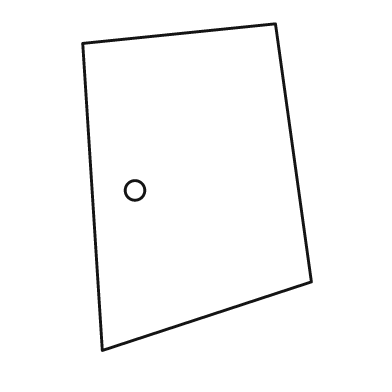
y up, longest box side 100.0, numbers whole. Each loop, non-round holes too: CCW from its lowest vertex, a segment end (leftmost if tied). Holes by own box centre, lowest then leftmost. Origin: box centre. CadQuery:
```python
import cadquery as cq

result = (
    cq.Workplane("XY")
    .moveTo(-29.0, -50.0)
    .lineTo(35.0, -29.0)
    .lineTo(24.0, 50.0)
    .lineTo(-35.0, 44.0)
    .close()
    .moveTo(-19.0, -1.0)
    .circle(3.0)
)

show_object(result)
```